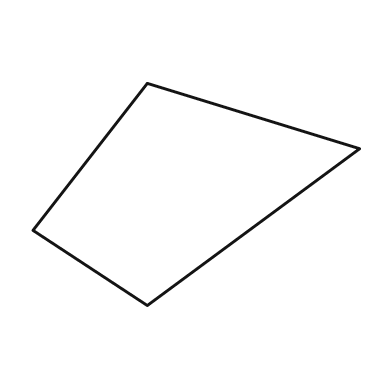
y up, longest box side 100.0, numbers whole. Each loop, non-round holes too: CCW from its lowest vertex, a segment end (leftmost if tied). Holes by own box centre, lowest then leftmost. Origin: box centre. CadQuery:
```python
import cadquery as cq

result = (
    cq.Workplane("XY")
    .moveTo(-15.0, -34.0)
    .lineTo(50.0, 14.0)
    .lineTo(-15.0, 34.0)
    .lineTo(-50.0, -11.0)
    .close()
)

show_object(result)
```